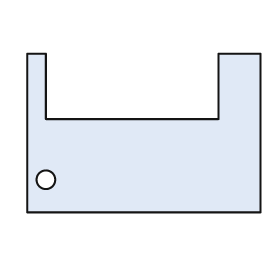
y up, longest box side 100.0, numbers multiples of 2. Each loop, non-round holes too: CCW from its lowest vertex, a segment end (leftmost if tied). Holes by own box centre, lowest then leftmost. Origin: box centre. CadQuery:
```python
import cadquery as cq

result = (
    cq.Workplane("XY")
    .moveTo(-50.0, -34.0)
    .lineTo(50.0, -34.0)
    .lineTo(50.0, 34.0)
    .lineTo(32.0, 34.0)
    .lineTo(32.0, 6.0)
    .lineTo(-42.0, 6.0)
    .lineTo(-42.0, 34.0)
    .lineTo(-50.0, 34.0)
    .close()
    .moveTo(-42.0, -20.0)
    .circle(4.0)
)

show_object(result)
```